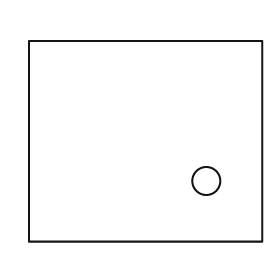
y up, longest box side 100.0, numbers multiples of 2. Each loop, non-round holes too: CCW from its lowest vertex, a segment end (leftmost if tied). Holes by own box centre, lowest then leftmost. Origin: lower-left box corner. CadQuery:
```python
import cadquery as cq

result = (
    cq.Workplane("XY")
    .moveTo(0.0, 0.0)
    .lineTo(100.0, 0.0)
    .lineTo(100.0, 86.0)
    .lineTo(0.0, 86.0)
    .close()
    .moveTo(76.0, 26.0)
    .circle(6.0)
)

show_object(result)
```